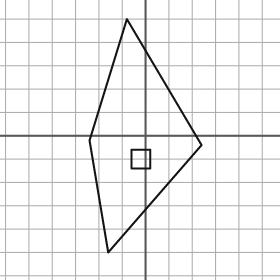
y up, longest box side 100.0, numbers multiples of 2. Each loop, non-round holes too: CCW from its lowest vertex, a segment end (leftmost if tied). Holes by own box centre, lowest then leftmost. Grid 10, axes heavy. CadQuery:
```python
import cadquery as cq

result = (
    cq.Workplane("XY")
    .moveTo(-16.0, -50.0)
    .lineTo(24.0, -4.0)
    .lineTo(-8.0, 50.0)
    .lineTo(-24.0, -2.0)
    .close()
    .moveTo(-6.0, -14.0)
    .lineTo(2.0, -14.0)
    .lineTo(2.0, -6.0)
    .lineTo(-6.0, -6.0)
    .close()
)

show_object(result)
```